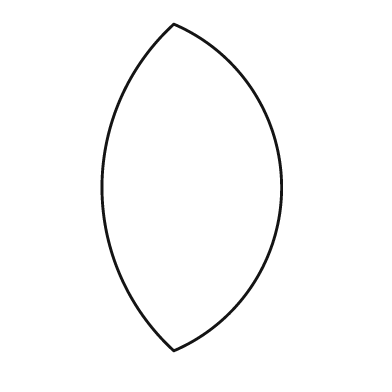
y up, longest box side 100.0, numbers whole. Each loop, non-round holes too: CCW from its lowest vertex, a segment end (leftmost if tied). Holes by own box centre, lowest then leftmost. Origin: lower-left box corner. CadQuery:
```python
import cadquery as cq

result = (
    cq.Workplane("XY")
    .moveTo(22.0, 0.0)
    .threePointArc((55.0, 50.0), (22.0, 100.0))
    .threePointArc((0.0, 50.0), (22.0, 0.0))
    .close()
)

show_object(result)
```